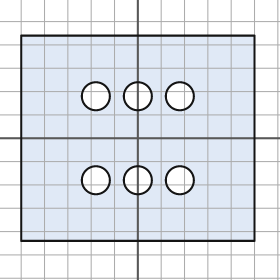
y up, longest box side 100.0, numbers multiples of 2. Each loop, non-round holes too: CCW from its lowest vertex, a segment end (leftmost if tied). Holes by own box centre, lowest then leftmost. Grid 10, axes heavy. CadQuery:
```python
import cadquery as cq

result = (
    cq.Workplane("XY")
    .moveTo(-50.0, -44.0)
    .lineTo(50.0, -44.0)
    .lineTo(50.0, 44.0)
    .lineTo(-50.0, 44.0)
    .close()
    .moveTo(-18.0, -18.0)
    .circle(6.0)
    .moveTo(0.0, -18.0)
    .circle(6.0)
    .moveTo(18.0, -18.0)
    .circle(6.0)
    .moveTo(-18.0, 18.0)
    .circle(6.0)
    .moveTo(0.0, 18.0)
    .circle(6.0)
    .moveTo(18.0, 18.0)
    .circle(6.0)
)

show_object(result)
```